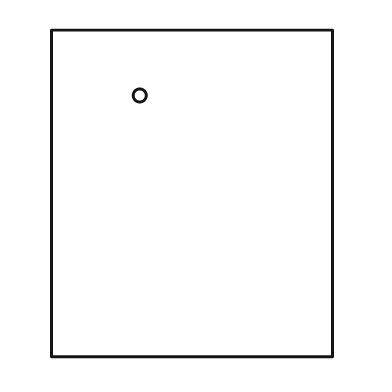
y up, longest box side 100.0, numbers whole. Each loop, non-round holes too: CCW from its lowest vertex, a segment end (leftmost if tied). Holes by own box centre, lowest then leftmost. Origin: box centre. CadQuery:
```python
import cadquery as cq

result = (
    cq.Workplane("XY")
    .moveTo(-43.0, -50.0)
    .lineTo(43.0, -50.0)
    .lineTo(43.0, 50.0)
    .lineTo(-43.0, 50.0)
    .close()
    .moveTo(-16.0, 30.0)
    .circle(2.0)
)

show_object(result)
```